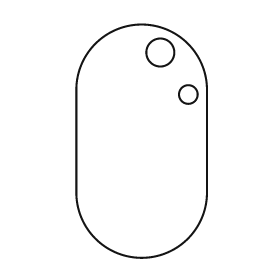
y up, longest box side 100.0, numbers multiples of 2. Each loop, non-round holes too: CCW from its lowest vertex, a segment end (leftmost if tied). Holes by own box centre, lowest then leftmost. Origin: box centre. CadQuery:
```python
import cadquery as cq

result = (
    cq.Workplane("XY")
    .moveTo(-28.0, -22.0)
    .threePointArc((0.0, -50.0), (28.0, -22.0))
    .lineTo(28.0, 22.0)
    .threePointArc((0.0, 50.0), (-28.0, 22.0))
    .close()
    .moveTo(20.0, 20.0)
    .circle(4.0)
    .moveTo(8.0, 38.0)
    .circle(6.0)
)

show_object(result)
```